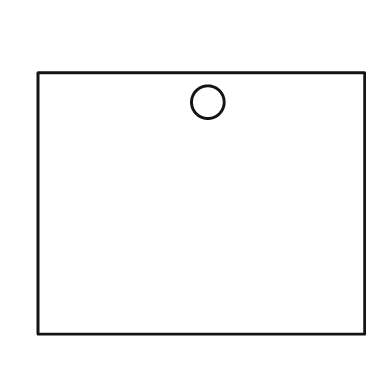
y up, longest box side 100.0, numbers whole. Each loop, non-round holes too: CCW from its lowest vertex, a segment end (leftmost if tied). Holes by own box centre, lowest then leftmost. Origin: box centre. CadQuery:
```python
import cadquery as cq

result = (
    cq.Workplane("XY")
    .moveTo(-50.0, -40.0)
    .lineTo(50.0, -40.0)
    .lineTo(50.0, 40.0)
    .lineTo(-50.0, 40.0)
    .close()
    .moveTo(2.0, 31.0)
    .circle(5.0)
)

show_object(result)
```